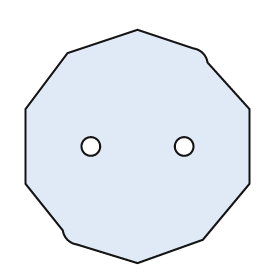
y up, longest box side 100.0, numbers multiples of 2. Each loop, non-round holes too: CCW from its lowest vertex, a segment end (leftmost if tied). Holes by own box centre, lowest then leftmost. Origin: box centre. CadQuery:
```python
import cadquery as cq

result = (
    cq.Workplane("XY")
    .moveTo(0.0, -50.0)
    .lineTo(28.0, -40.0)
    .lineTo(48.0, -16.0)
    .lineTo(48.0, 16.0)
    .lineTo(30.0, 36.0)
    .threePointArc((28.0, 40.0), (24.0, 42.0))
    .lineTo(0.0, 50.0)
    .lineTo(-30.0, 40.0)
    .lineTo(-48.0, 16.0)
    .lineTo(-48.0, -16.0)
    .lineTo(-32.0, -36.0)
    .threePointArc((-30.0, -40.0), (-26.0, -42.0))
    .close()
    .moveTo(-20.0, 0.0)
    .circle(4.0)
    .moveTo(20.0, 0.0)
    .circle(4.0)
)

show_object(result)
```